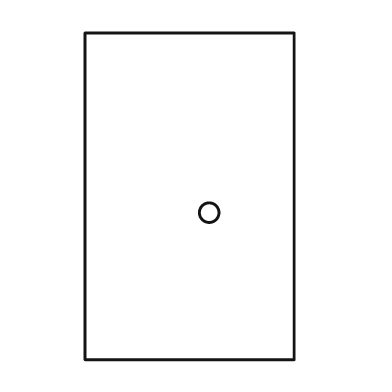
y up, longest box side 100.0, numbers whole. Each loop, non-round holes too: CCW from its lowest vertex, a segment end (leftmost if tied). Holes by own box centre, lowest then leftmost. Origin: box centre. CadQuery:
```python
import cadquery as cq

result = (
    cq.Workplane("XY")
    .moveTo(-32.0, -50.0)
    .lineTo(32.0, -50.0)
    .lineTo(32.0, 50.0)
    .lineTo(-32.0, 50.0)
    .close()
    .moveTo(6.0, -5.0)
    .circle(3.0)
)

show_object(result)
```